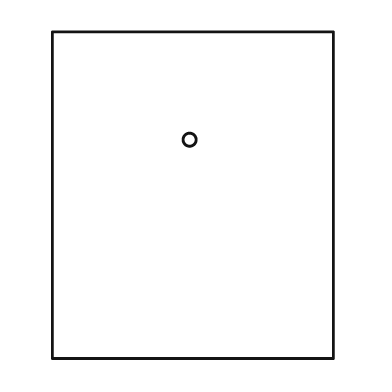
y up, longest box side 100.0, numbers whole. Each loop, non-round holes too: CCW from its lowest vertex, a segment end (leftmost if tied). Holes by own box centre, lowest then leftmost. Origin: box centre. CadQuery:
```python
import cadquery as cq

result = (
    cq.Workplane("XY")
    .moveTo(-43.0, -50.0)
    .lineTo(43.0, -50.0)
    .lineTo(43.0, 50.0)
    .lineTo(-43.0, 50.0)
    .close()
    .moveTo(-1.0, 17.0)
    .circle(2.0)
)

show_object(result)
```